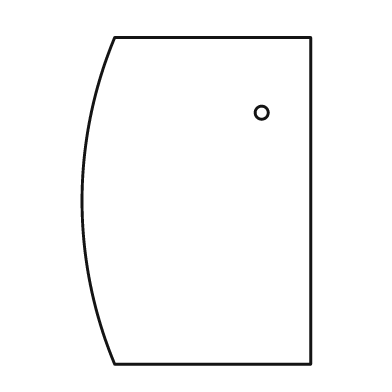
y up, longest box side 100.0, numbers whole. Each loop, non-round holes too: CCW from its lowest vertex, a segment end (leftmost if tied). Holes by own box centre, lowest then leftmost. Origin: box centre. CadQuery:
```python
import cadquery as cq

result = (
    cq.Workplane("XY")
    .moveTo(-25.0, -50.0)
    .lineTo(35.0, -50.0)
    .lineTo(35.0, 50.0)
    .lineTo(-25.0, 50.0)
    .threePointArc((-35.0, 0.0), (-25.0, -50.0))
    .close()
    .moveTo(20.0, 27.0)
    .circle(2.0)
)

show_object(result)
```